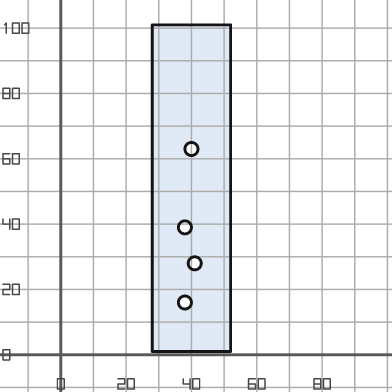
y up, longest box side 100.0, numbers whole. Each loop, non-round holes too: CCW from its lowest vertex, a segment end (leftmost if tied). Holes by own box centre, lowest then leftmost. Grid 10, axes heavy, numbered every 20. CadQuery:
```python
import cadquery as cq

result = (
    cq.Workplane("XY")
    .moveTo(28.0, 1.0)
    .lineTo(52.0, 1.0)
    .lineTo(52.0, 101.0)
    .lineTo(28.0, 101.0)
    .close()
    .moveTo(38.0, 16.0)
    .circle(2.0)
    .moveTo(41.0, 28.0)
    .circle(2.0)
    .moveTo(38.0, 39.0)
    .circle(2.0)
    .moveTo(40.0, 63.0)
    .circle(2.0)
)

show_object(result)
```